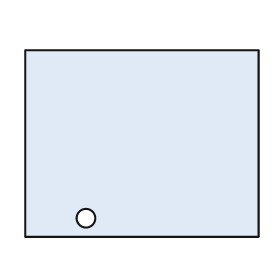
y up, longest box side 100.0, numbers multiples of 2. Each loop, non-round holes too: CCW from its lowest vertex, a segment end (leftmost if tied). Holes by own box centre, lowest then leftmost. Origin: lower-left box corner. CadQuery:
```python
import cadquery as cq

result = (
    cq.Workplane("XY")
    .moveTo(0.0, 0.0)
    .lineTo(100.0, 0.0)
    .lineTo(100.0, 80.0)
    .lineTo(0.0, 80.0)
    .close()
    .moveTo(26.0, 8.0)
    .circle(4.0)
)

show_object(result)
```